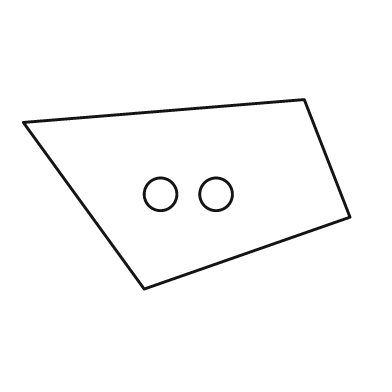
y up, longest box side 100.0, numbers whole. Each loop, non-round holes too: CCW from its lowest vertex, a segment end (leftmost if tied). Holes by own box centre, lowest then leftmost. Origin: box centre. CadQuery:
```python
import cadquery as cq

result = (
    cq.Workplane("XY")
    .moveTo(-13.0, -29.0)
    .lineTo(50.0, -7.0)
    .lineTo(36.0, 29.0)
    .lineTo(-50.0, 22.0)
    .close()
    .moveTo(-8.0, 0.0)
    .circle(5.0)
    .moveTo(9.0, 0.0)
    .circle(5.0)
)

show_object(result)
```